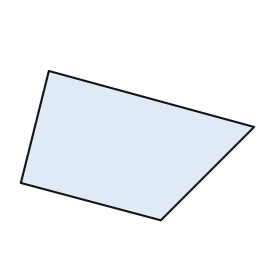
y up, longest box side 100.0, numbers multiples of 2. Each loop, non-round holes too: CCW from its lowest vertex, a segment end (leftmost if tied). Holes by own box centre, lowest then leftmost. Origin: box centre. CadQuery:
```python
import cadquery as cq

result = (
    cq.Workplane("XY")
    .moveTo(10.0, -32.0)
    .lineTo(50.0, 8.0)
    .lineTo(-38.0, 32.0)
    .lineTo(-50.0, -16.0)
    .close()
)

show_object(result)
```